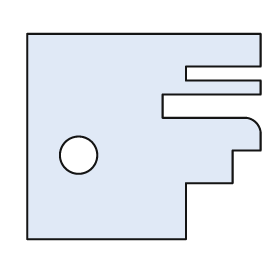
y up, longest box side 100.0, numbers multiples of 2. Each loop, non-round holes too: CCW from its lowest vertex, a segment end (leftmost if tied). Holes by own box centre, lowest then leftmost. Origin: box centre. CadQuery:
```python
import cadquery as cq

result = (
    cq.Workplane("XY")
    .moveTo(-50.0, -44.0)
    .lineTo(18.0, -44.0)
    .lineTo(18.0, -20.0)
    .lineTo(38.0, -20.0)
    .lineTo(38.0, -6.0)
    .lineTo(50.0, -6.0)
    .lineTo(50.0, 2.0)
    .threePointArc((48.0, 6.0), (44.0, 8.0))
    .lineTo(8.0, 8.0)
    .lineTo(8.0, 18.0)
    .lineTo(50.0, 18.0)
    .lineTo(50.0, 24.0)
    .lineTo(18.0, 24.0)
    .lineTo(18.0, 30.0)
    .lineTo(50.0, 30.0)
    .lineTo(50.0, 44.0)
    .lineTo(-50.0, 44.0)
    .close()
    .moveTo(-28.0, -8.0)
    .circle(8.0)
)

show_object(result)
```